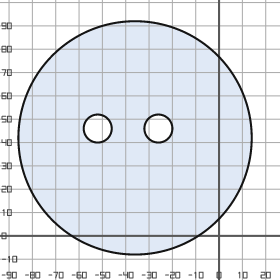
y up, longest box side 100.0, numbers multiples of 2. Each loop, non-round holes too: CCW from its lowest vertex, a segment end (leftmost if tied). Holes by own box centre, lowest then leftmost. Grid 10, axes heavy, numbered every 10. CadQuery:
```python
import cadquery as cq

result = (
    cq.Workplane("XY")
    .moveTo(-36.0, 42.0)
    .circle(50.0)
    .moveTo(-52.0, 46.0)
    .circle(6.0)
    .moveTo(-26.0, 46.0)
    .circle(6.0)
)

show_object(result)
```